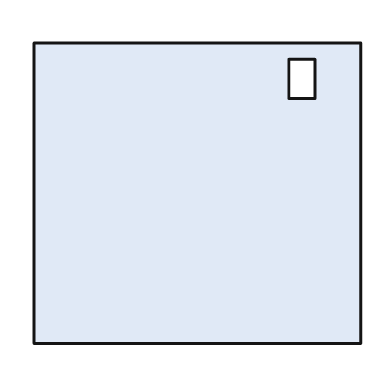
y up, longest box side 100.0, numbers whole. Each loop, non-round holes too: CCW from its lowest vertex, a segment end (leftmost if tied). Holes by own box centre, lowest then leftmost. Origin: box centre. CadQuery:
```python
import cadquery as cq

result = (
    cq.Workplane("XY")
    .moveTo(-50.0, -46.0)
    .lineTo(50.0, -46.0)
    .lineTo(50.0, 46.0)
    .lineTo(-50.0, 46.0)
    .close()
    .moveTo(28.0, 29.0)
    .lineTo(36.0, 29.0)
    .lineTo(36.0, 41.0)
    .lineTo(28.0, 41.0)
    .close()
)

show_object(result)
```